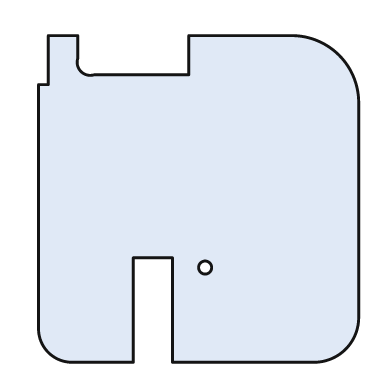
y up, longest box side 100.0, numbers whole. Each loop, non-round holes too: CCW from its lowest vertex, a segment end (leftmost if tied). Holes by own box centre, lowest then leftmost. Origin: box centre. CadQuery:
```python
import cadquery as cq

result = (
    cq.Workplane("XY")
    .moveTo(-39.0, -50.0)
    .lineTo(-20.0, -50.0)
    .lineTo(-20.0, -18.0)
    .lineTo(-8.0, -18.0)
    .lineTo(-8.0, -50.0)
    .lineTo(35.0, -50.0)
    .threePointArc((45.0, -46.0), (49.0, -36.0))
    .lineTo(49.0, 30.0)
    .threePointArc((43.0, 44.0), (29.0, 50.0))
    .lineTo(-3.0, 50.0)
    .lineTo(-3.0, 38.0)
    .lineTo(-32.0, 38.0)
    .threePointArc((-36.0, 39.0), (-37.0, 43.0))
    .lineTo(-37.0, 50.0)
    .lineTo(-46.0, 50.0)
    .lineTo(-46.0, 35.0)
    .lineTo(-49.0, 35.0)
    .lineTo(-49.0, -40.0)
    .threePointArc((-46.0, -47.0), (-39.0, -50.0))
    .close()
    .moveTo(2.0, -21.0)
    .circle(2.0)
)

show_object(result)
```